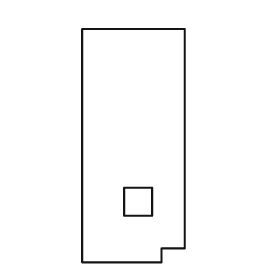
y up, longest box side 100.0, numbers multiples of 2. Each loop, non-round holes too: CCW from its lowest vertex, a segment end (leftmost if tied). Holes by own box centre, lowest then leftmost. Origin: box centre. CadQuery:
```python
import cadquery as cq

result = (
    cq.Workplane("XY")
    .moveTo(-22.0, -50.0)
    .lineTo(12.0, -50.0)
    .lineTo(12.0, -44.0)
    .lineTo(22.0, -44.0)
    .lineTo(22.0, 50.0)
    .lineTo(-22.0, 50.0)
    .close()
    .moveTo(-4.0, -30.0)
    .lineTo(8.0, -30.0)
    .lineTo(8.0, -18.0)
    .lineTo(-4.0, -18.0)
    .close()
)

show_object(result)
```